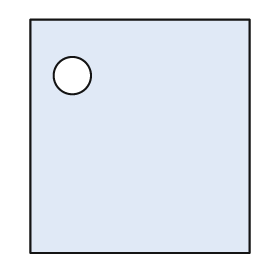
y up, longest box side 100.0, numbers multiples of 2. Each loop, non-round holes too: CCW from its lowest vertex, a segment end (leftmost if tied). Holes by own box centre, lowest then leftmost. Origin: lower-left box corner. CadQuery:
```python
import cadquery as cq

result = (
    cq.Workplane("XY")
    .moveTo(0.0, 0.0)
    .lineTo(94.0, 0.0)
    .lineTo(94.0, 100.0)
    .lineTo(0.0, 100.0)
    .close()
    .moveTo(18.0, 76.0)
    .circle(8.0)
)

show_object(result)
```